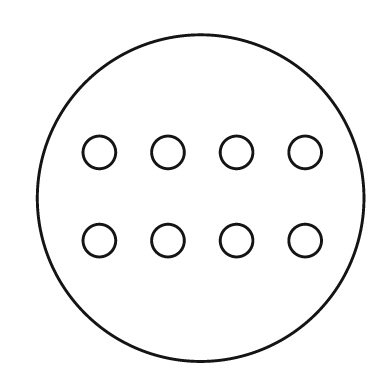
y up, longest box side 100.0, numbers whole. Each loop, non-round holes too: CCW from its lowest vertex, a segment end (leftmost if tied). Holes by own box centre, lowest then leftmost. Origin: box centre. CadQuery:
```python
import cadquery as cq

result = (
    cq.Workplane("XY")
    .moveTo(0.0, 0.0)
    .circle(50.0)
    .moveTo(-31.0, -13.0)
    .circle(5.0)
    .moveTo(-10.0, -13.0)
    .circle(5.0)
    .moveTo(11.0, -13.0)
    .circle(5.0)
    .moveTo(32.0, -13.0)
    .circle(5.0)
    .moveTo(-31.0, 14.0)
    .circle(5.0)
    .moveTo(-10.0, 14.0)
    .circle(5.0)
    .moveTo(11.0, 14.0)
    .circle(5.0)
    .moveTo(32.0, 14.0)
    .circle(5.0)
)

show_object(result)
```